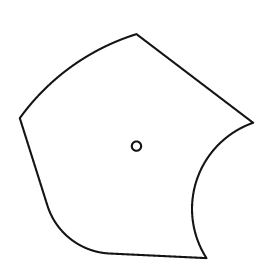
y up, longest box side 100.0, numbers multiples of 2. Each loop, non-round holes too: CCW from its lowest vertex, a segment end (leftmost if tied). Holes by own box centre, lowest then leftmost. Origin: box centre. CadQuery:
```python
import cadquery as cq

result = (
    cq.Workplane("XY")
    .moveTo(30.0, -48.0)
    .threePointArc((26.0, -14.0), (50.0, 10.0))
    .lineTo(0.0, 48.0)
    .threePointArc((-28.0, 34.0), (-50.0, 12.0))
    .lineTo(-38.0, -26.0)
    .threePointArc((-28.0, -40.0), (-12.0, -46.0))
    .close()
    .moveTo(0.0, 0.0)
    .circle(2.0)
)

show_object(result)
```